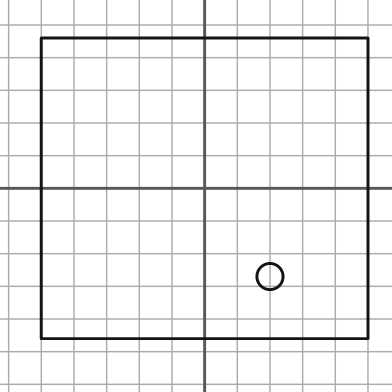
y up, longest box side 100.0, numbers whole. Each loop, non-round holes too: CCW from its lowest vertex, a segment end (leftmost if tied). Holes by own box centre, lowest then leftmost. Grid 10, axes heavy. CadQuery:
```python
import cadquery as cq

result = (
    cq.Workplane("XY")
    .moveTo(-50.0, -46.0)
    .lineTo(50.0, -46.0)
    .lineTo(50.0, 46.0)
    .lineTo(-50.0, 46.0)
    .close()
    .moveTo(20.0, -27.0)
    .circle(4.0)
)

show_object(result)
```